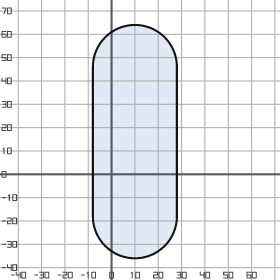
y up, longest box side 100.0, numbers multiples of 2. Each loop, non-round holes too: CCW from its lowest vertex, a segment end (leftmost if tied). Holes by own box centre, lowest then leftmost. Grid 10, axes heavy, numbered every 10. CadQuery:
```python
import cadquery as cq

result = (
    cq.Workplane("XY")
    .moveTo(-8.0, -18.0)
    .threePointArc((10.0, -36.0), (28.0, -18.0))
    .lineTo(28.0, 46.0)
    .threePointArc((10.0, 64.0), (-8.0, 46.0))
    .close()
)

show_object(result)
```